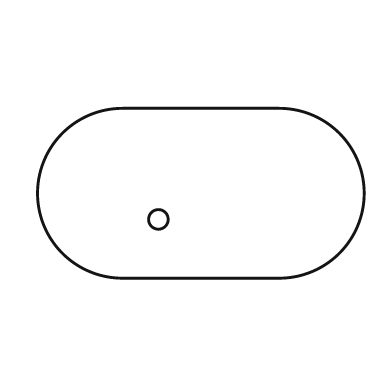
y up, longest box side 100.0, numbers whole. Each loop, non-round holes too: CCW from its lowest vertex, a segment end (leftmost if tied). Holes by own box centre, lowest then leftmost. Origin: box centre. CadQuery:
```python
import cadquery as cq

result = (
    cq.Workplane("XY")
    .moveTo(-24.0, -26.0)
    .lineTo(24.0, -26.0)
    .threePointArc((50.0, 0.0), (24.0, 26.0))
    .lineTo(-24.0, 26.0)
    .threePointArc((-50.0, 0.0), (-24.0, -26.0))
    .close()
    .moveTo(-13.0, -8.0)
    .circle(3.0)
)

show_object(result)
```